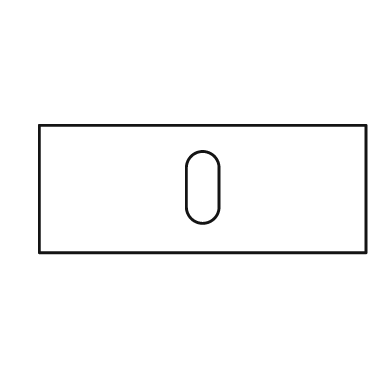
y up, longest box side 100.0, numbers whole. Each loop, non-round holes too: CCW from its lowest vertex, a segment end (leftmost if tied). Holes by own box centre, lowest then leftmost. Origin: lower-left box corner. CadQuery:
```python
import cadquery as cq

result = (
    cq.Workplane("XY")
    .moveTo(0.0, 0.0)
    .lineTo(100.0, 0.0)
    .lineTo(100.0, 39.0)
    .lineTo(0.0, 39.0)
    .close()
    .moveTo(45.0, 14.0)
    .threePointArc((50.0, 9.0), (55.0, 14.0))
    .lineTo(55.0, 26.0)
    .threePointArc((50.0, 31.0), (45.0, 26.0))
    .close()
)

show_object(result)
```